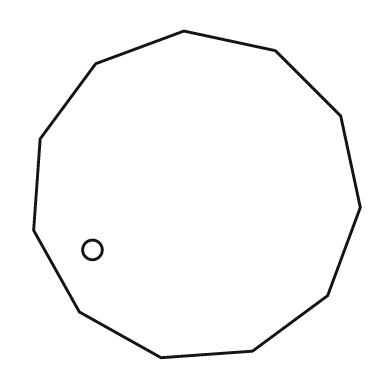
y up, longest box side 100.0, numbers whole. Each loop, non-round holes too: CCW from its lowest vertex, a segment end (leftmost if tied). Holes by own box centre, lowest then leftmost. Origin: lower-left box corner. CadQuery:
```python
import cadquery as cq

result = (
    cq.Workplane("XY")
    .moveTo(39.0, 0.0)
    .lineTo(67.0, 2.0)
    .lineTo(90.0, 19.0)
    .lineTo(100.0, 46.0)
    .lineTo(94.0, 74.0)
    .lineTo(74.0, 94.0)
    .lineTo(46.0, 100.0)
    .lineTo(19.0, 90.0)
    .lineTo(2.0, 67.0)
    .lineTo(0.0, 39.0)
    .lineTo(14.0, 14.0)
    .close()
    .moveTo(18.0, 33.0)
    .circle(3.0)
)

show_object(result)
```